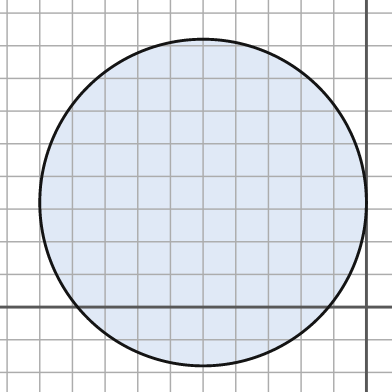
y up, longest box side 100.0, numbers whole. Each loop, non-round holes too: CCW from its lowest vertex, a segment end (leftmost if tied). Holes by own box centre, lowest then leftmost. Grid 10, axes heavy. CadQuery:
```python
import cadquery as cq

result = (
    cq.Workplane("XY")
    .moveTo(-50.0, 32.0)
    .circle(50.0)
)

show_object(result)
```